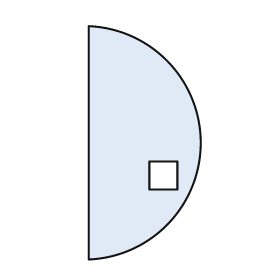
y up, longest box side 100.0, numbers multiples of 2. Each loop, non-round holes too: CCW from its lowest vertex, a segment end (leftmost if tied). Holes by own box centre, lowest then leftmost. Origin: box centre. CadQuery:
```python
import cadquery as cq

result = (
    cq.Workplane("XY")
    .moveTo(-24.0, -50.0)
    .threePointArc((24.0, 0.0), (-24.0, 50.0))
    .close()
    .moveTo(2.0, -20.0)
    .lineTo(14.0, -20.0)
    .lineTo(14.0, -8.0)
    .lineTo(2.0, -8.0)
    .close()
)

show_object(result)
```